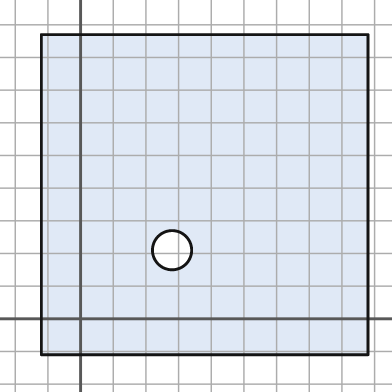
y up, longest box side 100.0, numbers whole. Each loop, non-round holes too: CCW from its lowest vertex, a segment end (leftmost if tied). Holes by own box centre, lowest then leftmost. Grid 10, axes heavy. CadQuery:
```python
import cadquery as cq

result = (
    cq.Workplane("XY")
    .moveTo(-12.0, -11.0)
    .lineTo(88.0, -11.0)
    .lineTo(88.0, 87.0)
    .lineTo(-12.0, 87.0)
    .close()
    .moveTo(28.0, 21.0)
    .circle(6.0)
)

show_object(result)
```